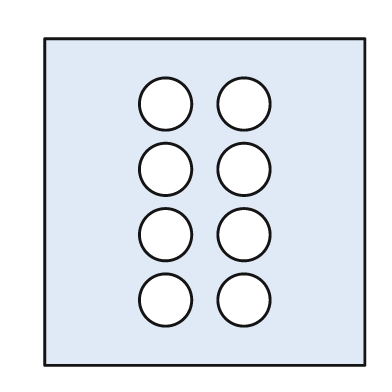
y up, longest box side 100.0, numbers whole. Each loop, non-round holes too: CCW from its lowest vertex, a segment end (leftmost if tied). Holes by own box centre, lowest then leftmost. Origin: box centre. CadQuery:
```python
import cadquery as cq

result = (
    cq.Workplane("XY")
    .moveTo(-49.0, -50.0)
    .lineTo(49.0, -50.0)
    .lineTo(49.0, 50.0)
    .lineTo(-49.0, 50.0)
    .close()
    .moveTo(-12.0, -30.0)
    .circle(8.0)
    .moveTo(12.0, -30.0)
    .circle(8.0)
    .moveTo(-12.0, -10.0)
    .circle(8.0)
    .moveTo(12.0, -10.0)
    .circle(8.0)
    .moveTo(-12.0, 10.0)
    .circle(8.0)
    .moveTo(12.0, 10.0)
    .circle(8.0)
    .moveTo(-12.0, 30.0)
    .circle(8.0)
    .moveTo(12.0, 30.0)
    .circle(8.0)
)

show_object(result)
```